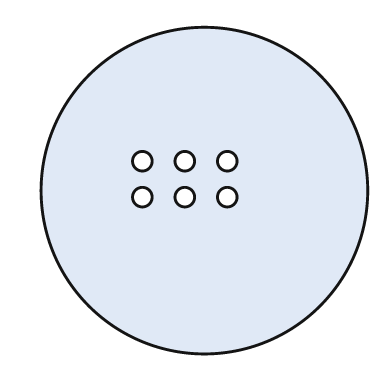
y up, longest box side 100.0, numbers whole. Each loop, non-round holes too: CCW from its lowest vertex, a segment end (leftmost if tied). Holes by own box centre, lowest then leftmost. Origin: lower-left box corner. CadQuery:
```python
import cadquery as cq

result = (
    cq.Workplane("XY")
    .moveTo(50.0, 50.0)
    .circle(50.0)
    .moveTo(31.0, 48.0)
    .circle(3.0)
    .moveTo(44.0, 48.0)
    .circle(3.0)
    .moveTo(57.0, 48.0)
    .circle(3.0)
    .moveTo(31.0, 59.0)
    .circle(3.0)
    .moveTo(44.0, 59.0)
    .circle(3.0)
    .moveTo(57.0, 59.0)
    .circle(3.0)
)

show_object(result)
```